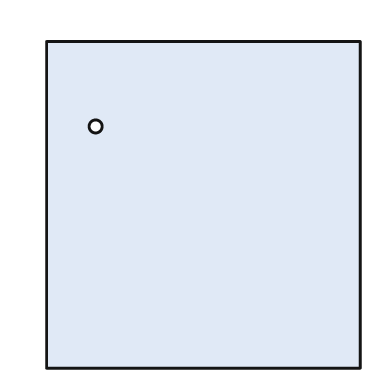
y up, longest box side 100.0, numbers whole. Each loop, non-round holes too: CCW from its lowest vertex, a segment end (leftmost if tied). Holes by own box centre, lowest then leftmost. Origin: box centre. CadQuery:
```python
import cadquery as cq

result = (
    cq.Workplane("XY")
    .moveTo(-48.0, -50.0)
    .lineTo(48.0, -50.0)
    .lineTo(48.0, 50.0)
    .lineTo(-48.0, 50.0)
    .close()
    .moveTo(-33.0, 24.0)
    .circle(2.0)
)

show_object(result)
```